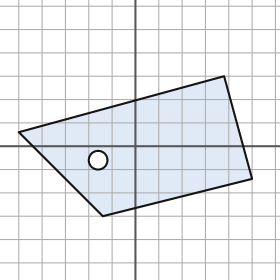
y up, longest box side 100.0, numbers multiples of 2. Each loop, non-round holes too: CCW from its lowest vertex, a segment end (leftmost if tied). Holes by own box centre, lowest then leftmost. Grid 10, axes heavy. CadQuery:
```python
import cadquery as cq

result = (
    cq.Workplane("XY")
    .moveTo(-14.0, -30.0)
    .lineTo(50.0, -14.0)
    .lineTo(38.0, 30.0)
    .lineTo(-50.0, 6.0)
    .close()
    .moveTo(-16.0, -6.0)
    .circle(4.0)
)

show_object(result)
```